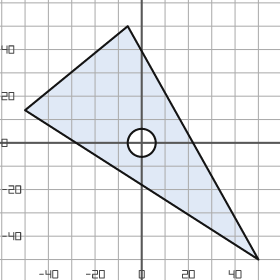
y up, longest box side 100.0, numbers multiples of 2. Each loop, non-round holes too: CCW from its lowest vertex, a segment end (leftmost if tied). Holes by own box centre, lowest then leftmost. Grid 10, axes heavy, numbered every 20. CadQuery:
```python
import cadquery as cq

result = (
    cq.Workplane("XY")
    .moveTo(50.0, -50.0)
    .lineTo(-6.0, 50.0)
    .lineTo(-50.0, 14.0)
    .close()
    .moveTo(0.0, 0.0)
    .circle(6.0)
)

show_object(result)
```